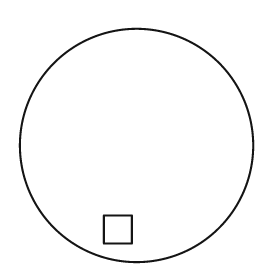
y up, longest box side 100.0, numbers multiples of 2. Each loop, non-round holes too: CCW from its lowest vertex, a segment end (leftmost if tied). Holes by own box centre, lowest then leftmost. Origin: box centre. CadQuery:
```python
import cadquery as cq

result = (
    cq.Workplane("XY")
    .moveTo(0.0, 0.0)
    .circle(50.0)
    .moveTo(-14.0, -42.0)
    .lineTo(-2.0, -42.0)
    .lineTo(-2.0, -30.0)
    .lineTo(-14.0, -30.0)
    .close()
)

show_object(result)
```